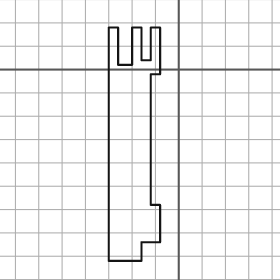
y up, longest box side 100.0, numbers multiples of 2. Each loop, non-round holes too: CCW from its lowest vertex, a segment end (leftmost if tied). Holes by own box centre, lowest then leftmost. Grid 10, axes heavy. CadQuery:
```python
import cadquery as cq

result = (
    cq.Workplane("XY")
    .moveTo(-30.0, -82.0)
    .lineTo(-16.0, -82.0)
    .lineTo(-16.0, -74.0)
    .lineTo(-8.0, -74.0)
    .lineTo(-8.0, -58.0)
    .lineTo(-12.0, -58.0)
    .lineTo(-12.0, -2.0)
    .lineTo(-8.0, -2.0)
    .lineTo(-8.0, 18.0)
    .lineTo(-12.0, 18.0)
    .lineTo(-12.0, 4.0)
    .lineTo(-16.0, 4.0)
    .lineTo(-16.0, 18.0)
    .lineTo(-20.0, 18.0)
    .lineTo(-20.0, 2.0)
    .lineTo(-26.0, 2.0)
    .lineTo(-26.0, 18.0)
    .lineTo(-30.0, 18.0)
    .close()
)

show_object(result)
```